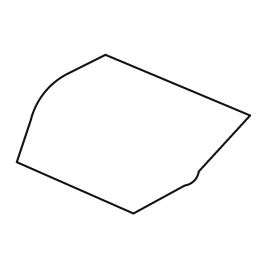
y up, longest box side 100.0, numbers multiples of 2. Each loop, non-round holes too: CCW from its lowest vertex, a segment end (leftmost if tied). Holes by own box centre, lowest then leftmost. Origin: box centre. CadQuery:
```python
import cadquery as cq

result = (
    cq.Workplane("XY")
    .moveTo(0.0, -34.0)
    .lineTo(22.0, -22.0)
    .threePointArc((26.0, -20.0), (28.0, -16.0))
    .lineTo(50.0, 8.0)
    .lineTo(-12.0, 34.0)
    .lineTo(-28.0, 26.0)
    .threePointArc((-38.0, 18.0), (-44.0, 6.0))
    .lineTo(-50.0, -12.0)
    .close()
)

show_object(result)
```